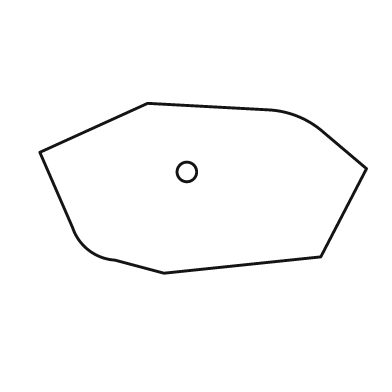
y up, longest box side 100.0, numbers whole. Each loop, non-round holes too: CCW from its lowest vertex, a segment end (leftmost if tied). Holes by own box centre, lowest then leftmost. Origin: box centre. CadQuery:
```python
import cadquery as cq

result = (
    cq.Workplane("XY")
    .moveTo(-12.0, -26.0)
    .lineTo(36.0, -21.0)
    .lineTo(50.0, 6.0)
    .lineTo(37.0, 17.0)
    .threePointArc((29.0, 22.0), (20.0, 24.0))
    .lineTo(-17.0, 26.0)
    .lineTo(-50.0, 11.0)
    .lineTo(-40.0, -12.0)
    .threePointArc((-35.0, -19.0), (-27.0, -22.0))
    .close()
    .moveTo(-5.0, 5.0)
    .circle(3.0)
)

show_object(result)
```